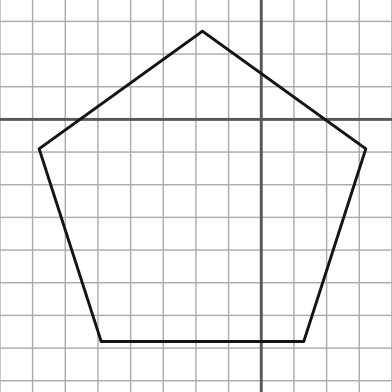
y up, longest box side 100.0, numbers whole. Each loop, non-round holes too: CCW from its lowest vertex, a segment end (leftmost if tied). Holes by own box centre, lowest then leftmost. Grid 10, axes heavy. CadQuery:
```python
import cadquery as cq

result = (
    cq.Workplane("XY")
    .moveTo(-49.0, -68.0)
    .lineTo(13.0, -68.0)
    .lineTo(32.0, -9.0)
    .lineTo(-18.0, 27.0)
    .lineTo(-68.0, -9.0)
    .close()
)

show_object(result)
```